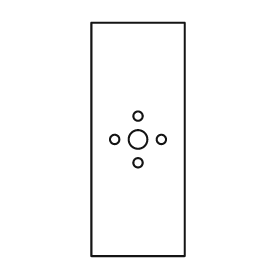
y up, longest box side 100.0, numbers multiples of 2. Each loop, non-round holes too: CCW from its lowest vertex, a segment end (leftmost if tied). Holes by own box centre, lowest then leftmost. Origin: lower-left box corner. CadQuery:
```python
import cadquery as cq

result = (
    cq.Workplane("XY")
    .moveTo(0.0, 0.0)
    .lineTo(40.0, 0.0)
    .lineTo(40.0, 100.0)
    .lineTo(0.0, 100.0)
    .close()
    .moveTo(20.0, 40.0)
    .circle(2.0)
    .moveTo(10.0, 50.0)
    .circle(2.0)
    .moveTo(20.0, 50.0)
    .circle(4.0)
    .moveTo(30.0, 50.0)
    .circle(2.0)
    .moveTo(20.0, 60.0)
    .circle(2.0)
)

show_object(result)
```